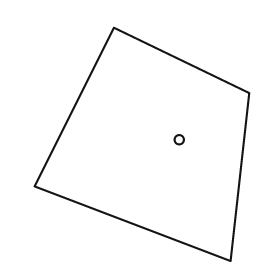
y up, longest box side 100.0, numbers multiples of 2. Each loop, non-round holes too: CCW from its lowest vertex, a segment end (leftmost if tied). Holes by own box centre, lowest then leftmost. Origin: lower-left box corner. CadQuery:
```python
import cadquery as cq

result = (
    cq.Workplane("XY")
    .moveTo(84.0, 0.0)
    .lineTo(92.0, 72.0)
    .lineTo(34.0, 100.0)
    .lineTo(0.0, 32.0)
    .close()
    .moveTo(62.0, 52.0)
    .circle(2.0)
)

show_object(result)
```